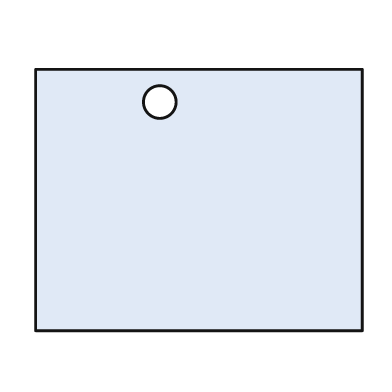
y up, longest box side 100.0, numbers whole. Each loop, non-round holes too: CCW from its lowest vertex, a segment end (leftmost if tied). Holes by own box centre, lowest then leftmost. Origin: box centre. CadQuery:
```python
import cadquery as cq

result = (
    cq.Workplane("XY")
    .moveTo(-50.0, -40.0)
    .lineTo(50.0, -40.0)
    .lineTo(50.0, 40.0)
    .lineTo(-50.0, 40.0)
    .close()
    .moveTo(-12.0, 30.0)
    .circle(5.0)
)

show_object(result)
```